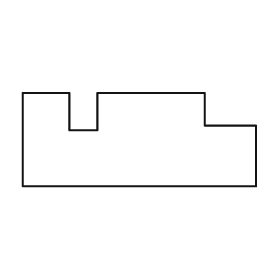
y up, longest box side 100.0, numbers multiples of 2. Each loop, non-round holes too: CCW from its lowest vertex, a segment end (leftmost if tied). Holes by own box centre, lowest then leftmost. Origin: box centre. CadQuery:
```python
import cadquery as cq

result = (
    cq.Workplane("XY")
    .moveTo(-50.0, -20.0)
    .lineTo(50.0, -20.0)
    .lineTo(50.0, 6.0)
    .lineTo(28.0, 6.0)
    .lineTo(28.0, 20.0)
    .lineTo(-18.0, 20.0)
    .lineTo(-18.0, 4.0)
    .lineTo(-30.0, 4.0)
    .lineTo(-30.0, 20.0)
    .lineTo(-50.0, 20.0)
    .close()
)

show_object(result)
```